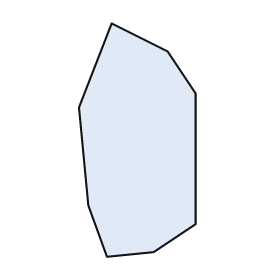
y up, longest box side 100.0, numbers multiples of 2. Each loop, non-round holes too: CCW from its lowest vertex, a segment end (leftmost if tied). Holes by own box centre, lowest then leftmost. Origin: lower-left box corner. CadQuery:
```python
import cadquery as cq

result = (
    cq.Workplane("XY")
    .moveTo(12.0, 0.0)
    .lineTo(32.0, 2.0)
    .lineTo(50.0, 14.0)
    .lineTo(50.0, 70.0)
    .lineTo(38.0, 88.0)
    .lineTo(14.0, 100.0)
    .lineTo(0.0, 64.0)
    .lineTo(4.0, 22.0)
    .close()
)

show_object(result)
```